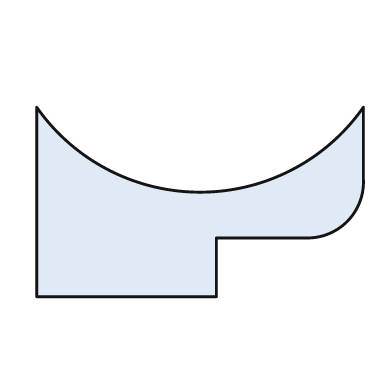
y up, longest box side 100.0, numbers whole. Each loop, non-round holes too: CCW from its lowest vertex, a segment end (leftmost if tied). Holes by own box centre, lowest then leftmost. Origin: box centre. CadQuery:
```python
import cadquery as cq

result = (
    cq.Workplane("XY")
    .moveTo(-50.0, -29.0)
    .lineTo(5.0, -29.0)
    .lineTo(5.0, -11.0)
    .lineTo(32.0, -11.0)
    .threePointArc((45.0, -6.0), (50.0, 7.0))
    .lineTo(50.0, 29.0)
    .threePointArc((0.0, 3.0), (-50.0, 29.0))
    .close()
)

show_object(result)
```